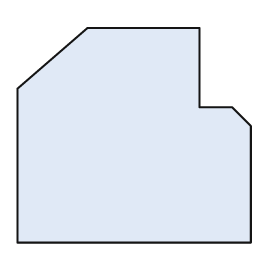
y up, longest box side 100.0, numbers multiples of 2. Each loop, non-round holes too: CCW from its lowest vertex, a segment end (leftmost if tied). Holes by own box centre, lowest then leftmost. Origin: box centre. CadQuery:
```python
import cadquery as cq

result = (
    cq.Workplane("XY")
    .moveTo(-50.0, -46.0)
    .lineTo(50.0, -46.0)
    .lineTo(50.0, 4.0)
    .lineTo(42.0, 12.0)
    .lineTo(28.0, 12.0)
    .lineTo(28.0, 46.0)
    .lineTo(-20.0, 46.0)
    .lineTo(-50.0, 20.0)
    .close()
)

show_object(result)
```